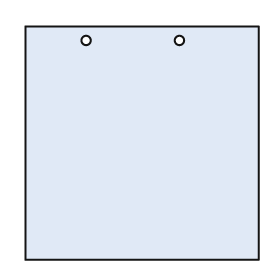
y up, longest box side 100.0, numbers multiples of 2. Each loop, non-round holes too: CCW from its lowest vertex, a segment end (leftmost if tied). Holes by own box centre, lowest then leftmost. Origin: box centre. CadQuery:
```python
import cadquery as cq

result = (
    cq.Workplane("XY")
    .moveTo(-50.0, -50.0)
    .lineTo(50.0, -50.0)
    .lineTo(50.0, 50.0)
    .lineTo(-50.0, 50.0)
    .close()
    .moveTo(-24.0, 44.0)
    .circle(2.0)
    .moveTo(16.0, 44.0)
    .circle(2.0)
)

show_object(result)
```